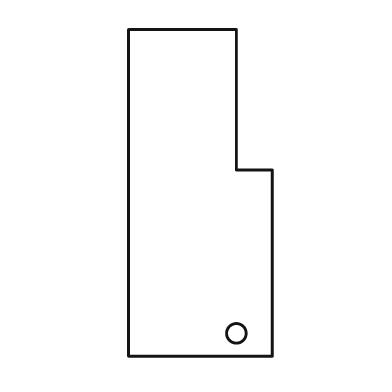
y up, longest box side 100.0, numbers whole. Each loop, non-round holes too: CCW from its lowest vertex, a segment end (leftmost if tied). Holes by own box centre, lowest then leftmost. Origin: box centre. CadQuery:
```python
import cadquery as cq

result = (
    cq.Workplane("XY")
    .moveTo(-22.0, -50.0)
    .lineTo(22.0, -50.0)
    .lineTo(22.0, 7.0)
    .lineTo(11.0, 7.0)
    .lineTo(11.0, 50.0)
    .lineTo(-22.0, 50.0)
    .close()
    .moveTo(11.0, -43.0)
    .circle(3.0)
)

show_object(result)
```